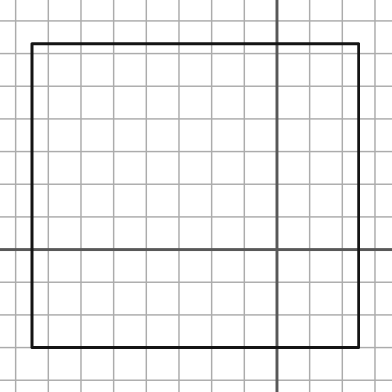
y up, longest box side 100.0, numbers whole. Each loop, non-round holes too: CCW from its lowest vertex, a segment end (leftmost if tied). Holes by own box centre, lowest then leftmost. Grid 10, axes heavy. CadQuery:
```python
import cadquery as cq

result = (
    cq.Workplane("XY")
    .moveTo(-75.0, -30.0)
    .lineTo(25.0, -30.0)
    .lineTo(25.0, 63.0)
    .lineTo(-75.0, 63.0)
    .close()
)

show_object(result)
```